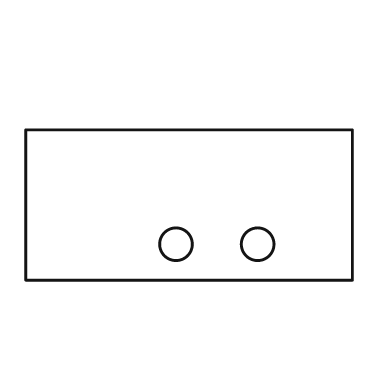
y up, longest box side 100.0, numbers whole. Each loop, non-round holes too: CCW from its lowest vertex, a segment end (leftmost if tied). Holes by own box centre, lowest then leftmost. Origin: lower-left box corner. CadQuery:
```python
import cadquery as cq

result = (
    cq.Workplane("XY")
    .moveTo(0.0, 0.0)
    .lineTo(100.0, 0.0)
    .lineTo(100.0, 46.0)
    .lineTo(0.0, 46.0)
    .close()
    .moveTo(46.0, 11.0)
    .circle(5.0)
    .moveTo(71.0, 11.0)
    .circle(5.0)
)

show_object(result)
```